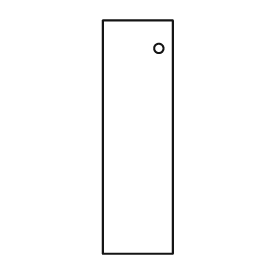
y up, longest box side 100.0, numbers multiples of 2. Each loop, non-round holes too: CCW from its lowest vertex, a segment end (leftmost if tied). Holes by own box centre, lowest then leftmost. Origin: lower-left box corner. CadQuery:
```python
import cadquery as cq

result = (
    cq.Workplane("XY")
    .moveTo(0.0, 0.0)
    .lineTo(30.0, 0.0)
    .lineTo(30.0, 100.0)
    .lineTo(0.0, 100.0)
    .close()
    .moveTo(24.0, 88.0)
    .circle(2.0)
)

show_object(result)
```